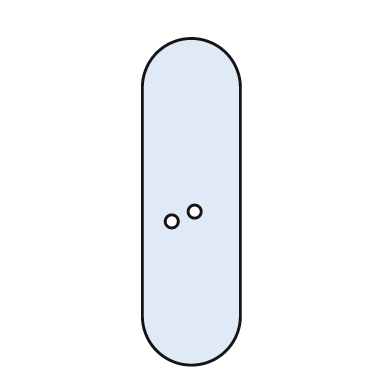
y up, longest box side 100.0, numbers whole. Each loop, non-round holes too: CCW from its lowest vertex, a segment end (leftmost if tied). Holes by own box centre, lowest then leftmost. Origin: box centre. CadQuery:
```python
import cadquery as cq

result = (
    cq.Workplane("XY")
    .moveTo(-15.0, -35.0)
    .threePointArc((0.0, -50.0), (15.0, -35.0))
    .lineTo(15.0, 35.0)
    .threePointArc((0.0, 50.0), (-15.0, 35.0))
    .close()
    .moveTo(-6.0, -6.0)
    .circle(2.0)
    .moveTo(1.0, -3.0)
    .circle(2.0)
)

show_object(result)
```